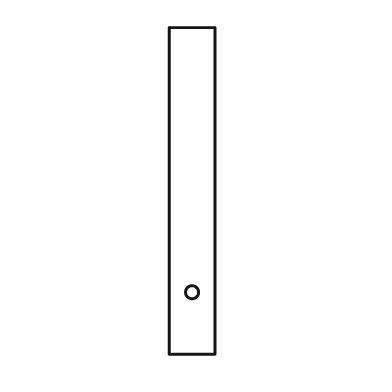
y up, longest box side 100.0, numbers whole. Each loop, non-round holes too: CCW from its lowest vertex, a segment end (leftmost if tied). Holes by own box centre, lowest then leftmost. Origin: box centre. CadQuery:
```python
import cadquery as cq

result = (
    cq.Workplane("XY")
    .moveTo(-7.0, -50.0)
    .lineTo(7.0, -50.0)
    .lineTo(7.0, 50.0)
    .lineTo(-7.0, 50.0)
    .close()
    .moveTo(0.0, -31.0)
    .circle(2.0)
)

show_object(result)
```